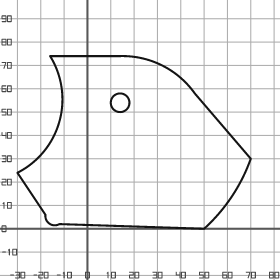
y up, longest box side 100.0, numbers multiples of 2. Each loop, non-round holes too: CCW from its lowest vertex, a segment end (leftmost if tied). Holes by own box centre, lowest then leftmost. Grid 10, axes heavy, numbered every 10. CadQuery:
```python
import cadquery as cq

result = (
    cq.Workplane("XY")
    .moveTo(50.0, 0.0)
    .threePointArc((62.0, 14.0), (70.0, 30.0))
    .lineTo(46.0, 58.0)
    .threePointArc((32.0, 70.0), (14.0, 74.0))
    .lineTo(-16.0, 74.0)
    .threePointArc((-12.0, 46.0), (-30.0, 24.0))
    .lineTo(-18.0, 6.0)
    .threePointArc((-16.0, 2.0), (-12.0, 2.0))
    .close()
    .moveTo(14.0, 54.0)
    .circle(4.0)
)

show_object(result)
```